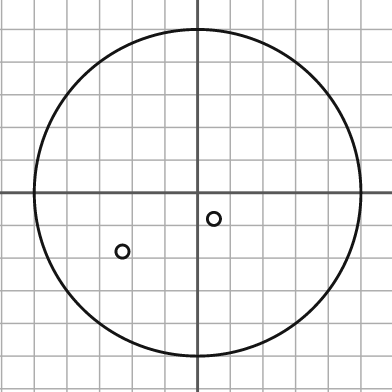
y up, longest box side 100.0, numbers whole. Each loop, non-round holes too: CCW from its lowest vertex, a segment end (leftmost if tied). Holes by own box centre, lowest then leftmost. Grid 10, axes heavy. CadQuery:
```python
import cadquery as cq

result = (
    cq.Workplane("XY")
    .moveTo(0.0, 0.0)
    .circle(50.0)
    .moveTo(-23.0, -18.0)
    .circle(2.0)
    .moveTo(5.0, -8.0)
    .circle(2.0)
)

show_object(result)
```